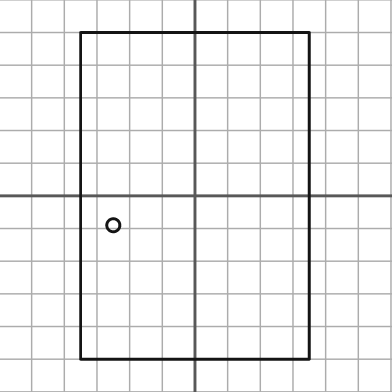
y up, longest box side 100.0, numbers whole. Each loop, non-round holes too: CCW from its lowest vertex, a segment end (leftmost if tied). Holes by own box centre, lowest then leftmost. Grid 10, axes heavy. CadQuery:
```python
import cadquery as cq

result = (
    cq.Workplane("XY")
    .moveTo(-35.0, -50.0)
    .lineTo(35.0, -50.0)
    .lineTo(35.0, 50.0)
    .lineTo(-35.0, 50.0)
    .close()
    .moveTo(-25.0, -9.0)
    .circle(2.0)
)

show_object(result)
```